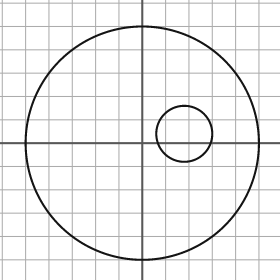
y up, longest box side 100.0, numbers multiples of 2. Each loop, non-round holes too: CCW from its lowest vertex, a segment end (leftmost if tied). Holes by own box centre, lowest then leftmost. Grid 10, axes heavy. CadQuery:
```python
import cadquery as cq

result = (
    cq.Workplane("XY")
    .moveTo(0.0, 0.0)
    .circle(50.0)
    .moveTo(18.0, 4.0)
    .circle(12.0)
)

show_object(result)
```